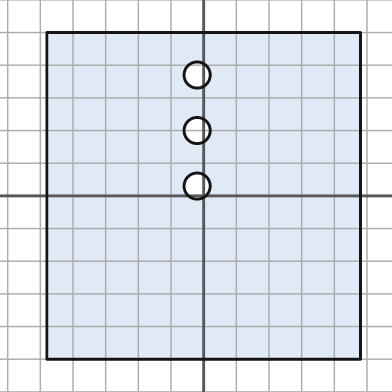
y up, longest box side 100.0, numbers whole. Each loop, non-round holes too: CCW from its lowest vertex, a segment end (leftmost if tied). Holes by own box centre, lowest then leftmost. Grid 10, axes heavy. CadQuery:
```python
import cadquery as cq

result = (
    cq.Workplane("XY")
    .moveTo(-48.0, -50.0)
    .lineTo(48.0, -50.0)
    .lineTo(48.0, 50.0)
    .lineTo(-48.0, 50.0)
    .close()
    .moveTo(-2.0, 3.0)
    .circle(4.0)
    .moveTo(-2.0, 20.0)
    .circle(4.0)
    .moveTo(-2.0, 37.0)
    .circle(4.0)
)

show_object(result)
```